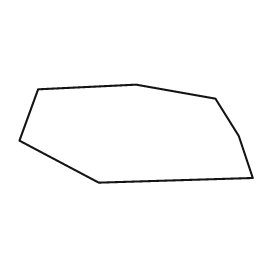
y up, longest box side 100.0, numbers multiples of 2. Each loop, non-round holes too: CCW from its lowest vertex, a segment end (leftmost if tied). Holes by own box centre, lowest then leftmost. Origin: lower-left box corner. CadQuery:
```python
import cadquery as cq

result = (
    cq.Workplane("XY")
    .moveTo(34.0, 0.0)
    .lineTo(100.0, 2.0)
    .lineTo(94.0, 20.0)
    .lineTo(84.0, 36.0)
    .lineTo(50.0, 42.0)
    .lineTo(8.0, 40.0)
    .lineTo(0.0, 18.0)
    .close()
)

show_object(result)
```